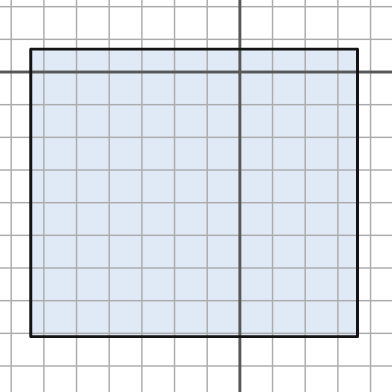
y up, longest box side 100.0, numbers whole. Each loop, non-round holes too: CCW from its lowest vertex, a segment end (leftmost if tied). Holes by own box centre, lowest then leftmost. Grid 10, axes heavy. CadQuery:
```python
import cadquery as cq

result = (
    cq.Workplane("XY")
    .moveTo(-64.0, -81.0)
    .lineTo(36.0, -81.0)
    .lineTo(36.0, 7.0)
    .lineTo(-64.0, 7.0)
    .close()
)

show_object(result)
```